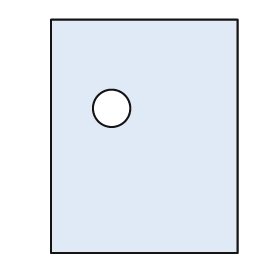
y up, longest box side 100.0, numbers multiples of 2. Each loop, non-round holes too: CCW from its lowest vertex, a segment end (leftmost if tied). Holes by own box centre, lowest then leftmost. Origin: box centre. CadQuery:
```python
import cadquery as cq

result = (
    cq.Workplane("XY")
    .moveTo(-40.0, -50.0)
    .lineTo(40.0, -50.0)
    .lineTo(40.0, 50.0)
    .lineTo(-40.0, 50.0)
    .close()
    .moveTo(-14.0, 12.0)
    .circle(8.0)
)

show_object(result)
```